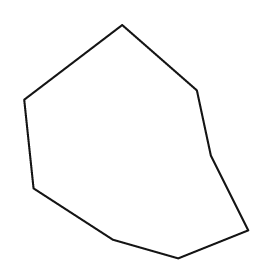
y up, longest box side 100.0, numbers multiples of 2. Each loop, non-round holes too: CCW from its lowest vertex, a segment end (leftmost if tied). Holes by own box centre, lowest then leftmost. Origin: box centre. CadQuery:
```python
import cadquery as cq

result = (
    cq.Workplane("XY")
    .moveTo(18.0, -50.0)
    .lineTo(48.0, -38.0)
    .lineTo(32.0, -6.0)
    .lineTo(26.0, 22.0)
    .lineTo(-6.0, 50.0)
    .lineTo(-48.0, 18.0)
    .lineTo(-44.0, -20.0)
    .lineTo(-10.0, -42.0)
    .close()
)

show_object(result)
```